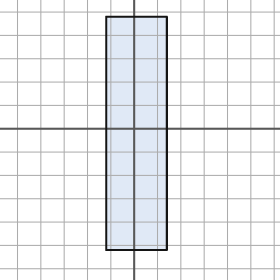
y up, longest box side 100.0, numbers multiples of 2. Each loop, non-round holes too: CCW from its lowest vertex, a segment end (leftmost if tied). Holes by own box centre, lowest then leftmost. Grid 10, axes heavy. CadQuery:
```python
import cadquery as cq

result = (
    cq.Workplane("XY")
    .moveTo(-12.0, -52.0)
    .lineTo(14.0, -52.0)
    .lineTo(14.0, 48.0)
    .lineTo(-12.0, 48.0)
    .close()
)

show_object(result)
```